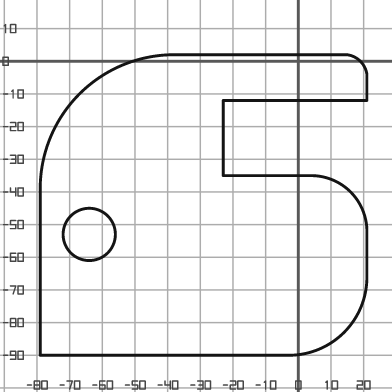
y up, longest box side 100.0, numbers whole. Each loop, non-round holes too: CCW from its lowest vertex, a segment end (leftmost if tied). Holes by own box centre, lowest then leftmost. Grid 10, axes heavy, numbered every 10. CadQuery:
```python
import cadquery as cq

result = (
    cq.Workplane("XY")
    .moveTo(-79.0, -90.0)
    .lineTo(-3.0, -90.0)
    .threePointArc((14.0, -83.0), (21.0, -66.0))
    .lineTo(21.0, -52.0)
    .threePointArc((16.0, -40.0), (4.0, -35.0))
    .lineTo(-23.0, -35.0)
    .lineTo(-23.0, -12.0)
    .lineTo(21.0, -12.0)
    .lineTo(21.0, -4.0)
    .threePointArc((19.0, 0.0), (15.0, 2.0))
    .lineTo(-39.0, 2.0)
    .threePointArc((-67.0, -10.0), (-79.0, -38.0))
    .close()
    .moveTo(-64.0, -53.0)
    .circle(8.0)
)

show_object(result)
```